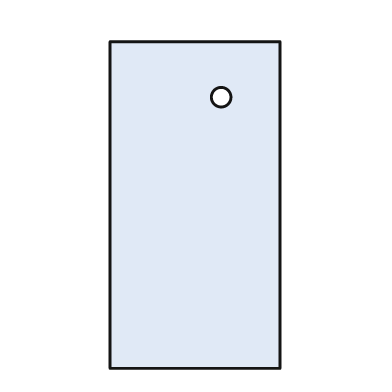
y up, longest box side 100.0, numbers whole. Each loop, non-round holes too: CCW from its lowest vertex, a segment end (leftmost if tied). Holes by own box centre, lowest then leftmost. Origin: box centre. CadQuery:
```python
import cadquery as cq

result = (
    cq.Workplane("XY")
    .moveTo(-26.0, -50.0)
    .lineTo(26.0, -50.0)
    .lineTo(26.0, 50.0)
    .lineTo(-26.0, 50.0)
    .close()
    .moveTo(8.0, 33.0)
    .circle(3.0)
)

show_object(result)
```